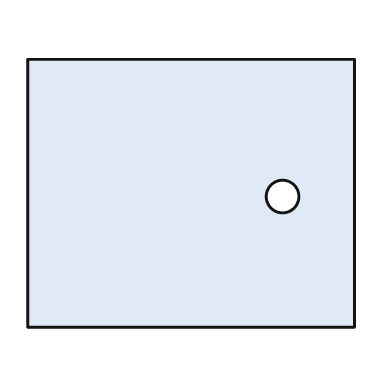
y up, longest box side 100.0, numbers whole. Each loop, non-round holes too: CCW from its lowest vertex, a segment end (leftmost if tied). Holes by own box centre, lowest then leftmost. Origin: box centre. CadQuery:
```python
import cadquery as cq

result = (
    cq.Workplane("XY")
    .moveTo(-50.0, -41.0)
    .lineTo(50.0, -41.0)
    .lineTo(50.0, 41.0)
    .lineTo(-50.0, 41.0)
    .close()
    .moveTo(28.0, -1.0)
    .circle(5.0)
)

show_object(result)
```